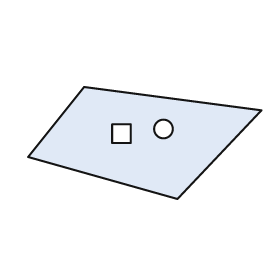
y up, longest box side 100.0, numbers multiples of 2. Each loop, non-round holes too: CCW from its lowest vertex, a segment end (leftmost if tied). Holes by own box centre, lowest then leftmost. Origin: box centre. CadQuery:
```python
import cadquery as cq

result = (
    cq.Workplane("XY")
    .moveTo(14.0, -24.0)
    .lineTo(50.0, 14.0)
    .lineTo(-26.0, 24.0)
    .lineTo(-50.0, -6.0)
    .close()
    .moveTo(-14.0, 0.0)
    .lineTo(-6.0, 0.0)
    .lineTo(-6.0, 8.0)
    .lineTo(-14.0, 8.0)
    .close()
    .moveTo(8.0, 6.0)
    .circle(4.0)
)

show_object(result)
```